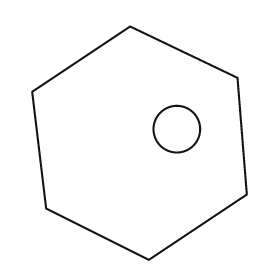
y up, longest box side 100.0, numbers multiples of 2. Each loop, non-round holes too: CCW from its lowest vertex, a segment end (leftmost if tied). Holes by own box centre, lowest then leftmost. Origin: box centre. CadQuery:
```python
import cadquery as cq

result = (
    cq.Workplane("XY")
    .moveTo(4.0, -50.0)
    .lineTo(46.0, -22.0)
    .lineTo(42.0, 28.0)
    .lineTo(-4.0, 50.0)
    .lineTo(-46.0, 22.0)
    .lineTo(-40.0, -28.0)
    .close()
    .moveTo(16.0, 6.0)
    .circle(10.0)
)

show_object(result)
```